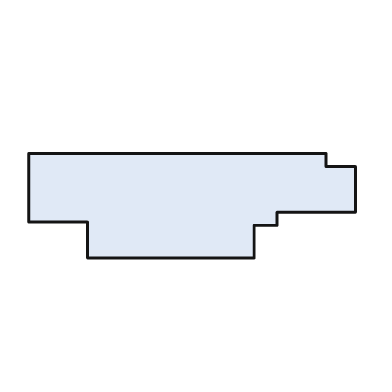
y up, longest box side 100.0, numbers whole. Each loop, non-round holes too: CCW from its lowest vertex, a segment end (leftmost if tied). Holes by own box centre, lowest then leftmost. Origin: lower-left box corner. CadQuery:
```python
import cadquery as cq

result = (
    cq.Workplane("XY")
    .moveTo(18.0, 0.0)
    .lineTo(69.0, 0.0)
    .lineTo(69.0, 10.0)
    .lineTo(76.0, 10.0)
    .lineTo(76.0, 14.0)
    .lineTo(100.0, 14.0)
    .lineTo(100.0, 28.0)
    .lineTo(91.0, 28.0)
    .lineTo(91.0, 32.0)
    .lineTo(0.0, 32.0)
    .lineTo(0.0, 11.0)
    .lineTo(18.0, 11.0)
    .close()
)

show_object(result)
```